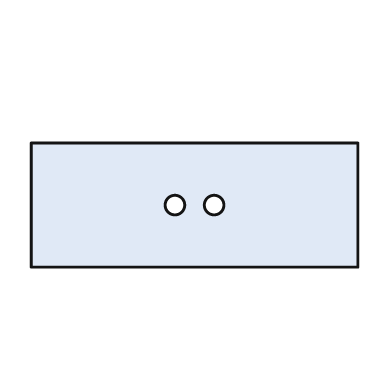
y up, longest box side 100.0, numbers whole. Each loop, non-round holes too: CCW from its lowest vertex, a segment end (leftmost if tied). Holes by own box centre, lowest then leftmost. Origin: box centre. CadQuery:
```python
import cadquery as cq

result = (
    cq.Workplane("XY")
    .moveTo(-50.0, -19.0)
    .lineTo(50.0, -19.0)
    .lineTo(50.0, 19.0)
    .lineTo(-50.0, 19.0)
    .close()
    .moveTo(-6.0, 0.0)
    .circle(3.0)
    .moveTo(6.0, 0.0)
    .circle(3.0)
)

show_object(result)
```